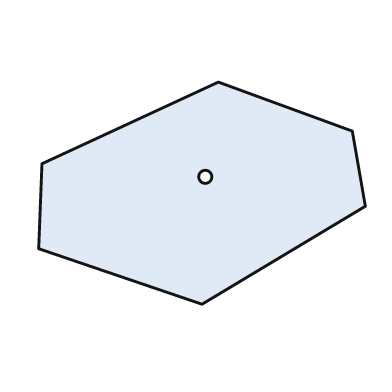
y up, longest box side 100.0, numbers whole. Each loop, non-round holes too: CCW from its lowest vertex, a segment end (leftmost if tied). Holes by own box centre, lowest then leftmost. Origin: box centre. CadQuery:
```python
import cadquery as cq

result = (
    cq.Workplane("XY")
    .moveTo(0.0, -34.0)
    .lineTo(50.0, -4.0)
    .lineTo(46.0, 19.0)
    .lineTo(5.0, 34.0)
    .lineTo(-49.0, 9.0)
    .lineTo(-50.0, -17.0)
    .close()
    .moveTo(1.0, 5.0)
    .circle(2.0)
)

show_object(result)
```